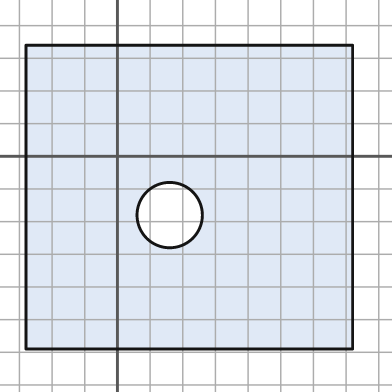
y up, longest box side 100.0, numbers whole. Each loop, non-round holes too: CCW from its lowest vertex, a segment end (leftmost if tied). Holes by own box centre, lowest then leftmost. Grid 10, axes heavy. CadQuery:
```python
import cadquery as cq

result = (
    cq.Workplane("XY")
    .moveTo(-28.0, -59.0)
    .lineTo(72.0, -59.0)
    .lineTo(72.0, 34.0)
    .lineTo(-28.0, 34.0)
    .close()
    .moveTo(16.0, -18.0)
    .circle(10.0)
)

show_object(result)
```